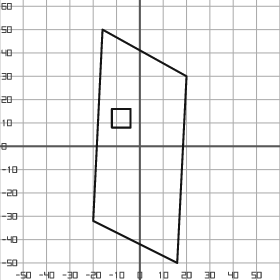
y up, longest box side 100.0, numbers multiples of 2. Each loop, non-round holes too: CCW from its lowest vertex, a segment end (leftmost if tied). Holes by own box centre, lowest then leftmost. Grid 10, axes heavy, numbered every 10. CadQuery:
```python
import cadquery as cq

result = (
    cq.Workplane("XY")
    .moveTo(16.0, -50.0)
    .lineTo(20.0, 30.0)
    .lineTo(-16.0, 50.0)
    .lineTo(-20.0, -32.0)
    .close()
    .moveTo(-12.0, 8.0)
    .lineTo(-4.0, 8.0)
    .lineTo(-4.0, 16.0)
    .lineTo(-12.0, 16.0)
    .close()
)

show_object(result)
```